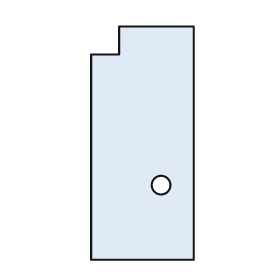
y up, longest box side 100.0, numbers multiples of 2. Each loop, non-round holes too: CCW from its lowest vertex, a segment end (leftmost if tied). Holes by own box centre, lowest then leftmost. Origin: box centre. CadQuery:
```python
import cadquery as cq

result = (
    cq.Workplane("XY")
    .moveTo(-22.0, -50.0)
    .lineTo(22.0, -50.0)
    .lineTo(22.0, 50.0)
    .lineTo(-10.0, 50.0)
    .lineTo(-10.0, 38.0)
    .lineTo(-22.0, 38.0)
    .close()
    .moveTo(8.0, -18.0)
    .circle(4.0)
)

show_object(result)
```